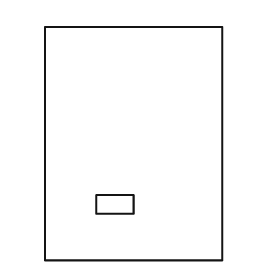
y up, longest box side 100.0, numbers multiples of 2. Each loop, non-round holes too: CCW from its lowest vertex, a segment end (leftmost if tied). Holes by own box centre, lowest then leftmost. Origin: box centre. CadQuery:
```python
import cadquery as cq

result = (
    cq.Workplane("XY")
    .moveTo(-38.0, -50.0)
    .lineTo(38.0, -50.0)
    .lineTo(38.0, 50.0)
    .lineTo(-38.0, 50.0)
    .close()
    .moveTo(-16.0, -30.0)
    .lineTo(0.0, -30.0)
    .lineTo(0.0, -22.0)
    .lineTo(-16.0, -22.0)
    .close()
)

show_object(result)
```